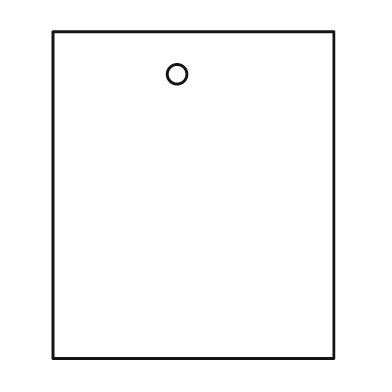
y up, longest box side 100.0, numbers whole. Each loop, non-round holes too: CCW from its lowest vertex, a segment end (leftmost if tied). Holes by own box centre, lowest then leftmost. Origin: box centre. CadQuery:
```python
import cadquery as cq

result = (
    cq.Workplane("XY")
    .moveTo(-43.0, -50.0)
    .lineTo(43.0, -50.0)
    .lineTo(43.0, 50.0)
    .lineTo(-43.0, 50.0)
    .close()
    .moveTo(-5.0, 37.0)
    .circle(3.0)
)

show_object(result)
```